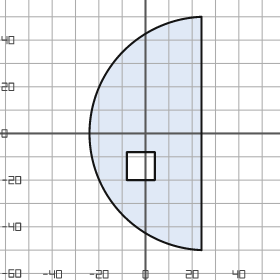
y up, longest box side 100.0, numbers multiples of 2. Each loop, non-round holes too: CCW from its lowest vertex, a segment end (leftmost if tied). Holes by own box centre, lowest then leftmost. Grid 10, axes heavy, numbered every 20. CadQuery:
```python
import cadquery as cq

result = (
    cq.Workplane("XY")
    .moveTo(24.0, -50.0)
    .lineTo(24.0, 50.0)
    .threePointArc((-24.0, 0.0), (24.0, -50.0))
    .close()
    .moveTo(-8.0, -20.0)
    .lineTo(4.0, -20.0)
    .lineTo(4.0, -8.0)
    .lineTo(-8.0, -8.0)
    .close()
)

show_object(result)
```